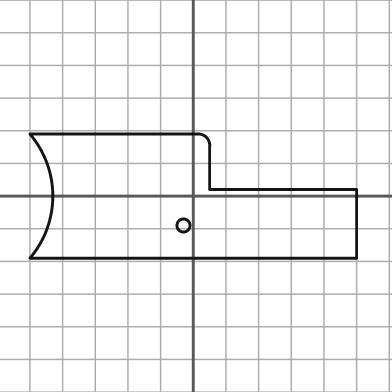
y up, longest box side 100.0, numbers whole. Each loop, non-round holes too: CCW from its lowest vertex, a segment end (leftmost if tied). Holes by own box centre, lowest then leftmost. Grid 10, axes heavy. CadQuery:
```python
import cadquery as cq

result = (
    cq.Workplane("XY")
    .moveTo(-50.0, -19.0)
    .lineTo(50.0, -19.0)
    .lineTo(50.0, 2.0)
    .lineTo(5.0, 2.0)
    .lineTo(5.0, 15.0)
    .threePointArc((4.0, 18.0), (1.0, 19.0))
    .lineTo(-50.0, 19.0)
    .threePointArc((-43.0, 0.0), (-50.0, -19.0))
    .close()
    .moveTo(-3.0, -9.0)
    .circle(2.0)
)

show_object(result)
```